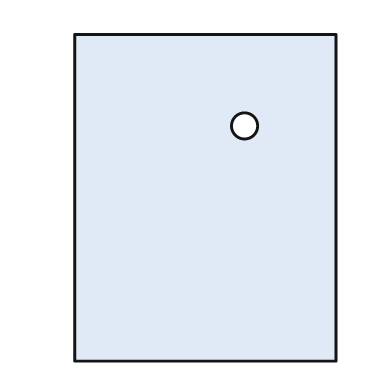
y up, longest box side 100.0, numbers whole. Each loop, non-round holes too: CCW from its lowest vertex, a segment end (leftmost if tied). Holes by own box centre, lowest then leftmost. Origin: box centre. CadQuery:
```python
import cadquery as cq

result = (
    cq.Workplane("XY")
    .moveTo(-40.0, -50.0)
    .lineTo(40.0, -50.0)
    .lineTo(40.0, 50.0)
    .lineTo(-40.0, 50.0)
    .close()
    .moveTo(12.0, 22.0)
    .circle(4.0)
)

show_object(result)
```